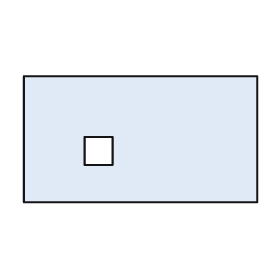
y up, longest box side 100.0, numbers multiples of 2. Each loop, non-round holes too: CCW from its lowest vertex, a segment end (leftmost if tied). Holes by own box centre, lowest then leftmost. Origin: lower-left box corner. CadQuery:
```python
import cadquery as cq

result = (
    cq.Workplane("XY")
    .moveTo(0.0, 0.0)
    .lineTo(100.0, 0.0)
    .lineTo(100.0, 54.0)
    .lineTo(0.0, 54.0)
    .close()
    .moveTo(26.0, 16.0)
    .lineTo(38.0, 16.0)
    .lineTo(38.0, 28.0)
    .lineTo(26.0, 28.0)
    .close()
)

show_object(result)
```